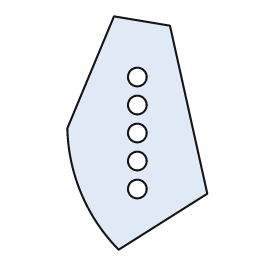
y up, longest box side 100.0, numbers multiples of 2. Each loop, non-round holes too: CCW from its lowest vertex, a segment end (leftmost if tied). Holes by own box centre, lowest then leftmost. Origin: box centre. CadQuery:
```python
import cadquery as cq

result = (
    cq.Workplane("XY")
    .moveTo(-8.0, -50.0)
    .lineTo(30.0, -26.0)
    .lineTo(14.0, 46.0)
    .lineTo(-10.0, 50.0)
    .lineTo(-30.0, 2.0)
    .threePointArc((-24.0, -26.0), (-8.0, -50.0))
    .close()
    .moveTo(0.0, -24.0)
    .circle(4.0)
    .moveTo(0.0, -12.0)
    .circle(4.0)
    .moveTo(0.0, 0.0)
    .circle(4.0)
    .moveTo(0.0, 12.0)
    .circle(4.0)
    .moveTo(0.0, 24.0)
    .circle(4.0)
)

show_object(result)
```